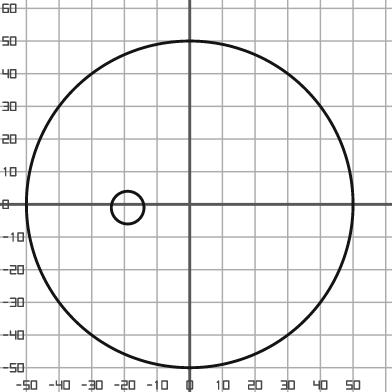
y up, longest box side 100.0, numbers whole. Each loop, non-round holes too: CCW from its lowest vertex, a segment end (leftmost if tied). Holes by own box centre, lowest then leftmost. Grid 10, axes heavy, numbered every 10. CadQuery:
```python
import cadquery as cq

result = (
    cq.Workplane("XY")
    .moveTo(0.0, 0.0)
    .circle(50.0)
    .moveTo(-19.0, -1.0)
    .circle(5.0)
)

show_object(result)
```